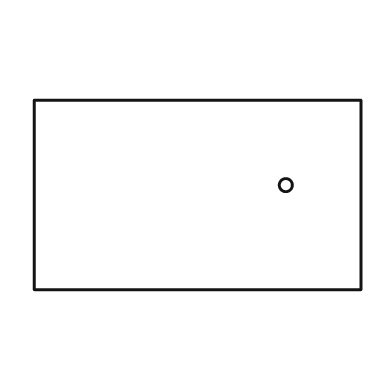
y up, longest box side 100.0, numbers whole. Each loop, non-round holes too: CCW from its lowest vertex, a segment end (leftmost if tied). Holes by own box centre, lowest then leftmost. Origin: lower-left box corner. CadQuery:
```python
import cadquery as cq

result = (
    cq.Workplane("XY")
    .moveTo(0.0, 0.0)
    .lineTo(100.0, 0.0)
    .lineTo(100.0, 58.0)
    .lineTo(0.0, 58.0)
    .close()
    .moveTo(77.0, 32.0)
    .circle(2.0)
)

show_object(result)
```